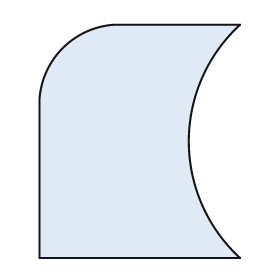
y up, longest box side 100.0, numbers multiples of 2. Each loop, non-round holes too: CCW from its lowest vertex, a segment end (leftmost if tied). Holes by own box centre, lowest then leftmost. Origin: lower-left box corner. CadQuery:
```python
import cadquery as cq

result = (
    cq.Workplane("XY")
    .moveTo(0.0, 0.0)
    .lineTo(86.0, 0.0)
    .threePointArc((64.0, 50.0), (86.0, 100.0))
    .lineTo(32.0, 100.0)
    .threePointArc((10.0, 90.0), (0.0, 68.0))
    .close()
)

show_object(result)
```